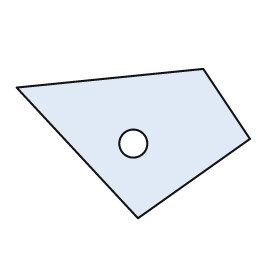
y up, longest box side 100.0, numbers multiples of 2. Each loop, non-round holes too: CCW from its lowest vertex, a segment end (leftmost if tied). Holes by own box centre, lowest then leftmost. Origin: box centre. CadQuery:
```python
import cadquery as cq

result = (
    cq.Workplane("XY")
    .moveTo(2.0, -32.0)
    .lineTo(50.0, 2.0)
    .lineTo(30.0, 32.0)
    .lineTo(-50.0, 24.0)
    .close()
    .moveTo(0.0, 0.0)
    .circle(6.0)
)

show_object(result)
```